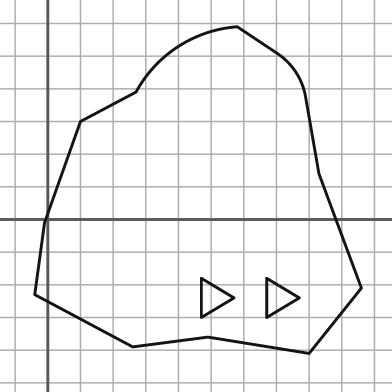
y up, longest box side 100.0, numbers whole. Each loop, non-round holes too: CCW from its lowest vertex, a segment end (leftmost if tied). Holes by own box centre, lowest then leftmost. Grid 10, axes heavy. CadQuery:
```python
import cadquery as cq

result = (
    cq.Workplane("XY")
    .moveTo(80.0, -41.0)
    .lineTo(96.0, -21.0)
    .lineTo(83.0, 14.0)
    .lineTo(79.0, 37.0)
    .threePointArc((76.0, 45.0), (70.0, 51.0))
    .lineTo(58.0, 59.0)
    .threePointArc((40.0, 53.0), (27.0, 39.0))
    .lineTo(10.0, 30.0)
    .lineTo(-1.0, -1.0)
    .lineTo(-4.0, -23.0)
    .lineTo(26.0, -39.0)
    .lineTo(49.0, -36.0)
    .close()
    .moveTo(47.0, -30.0)
    .lineTo(57.0, -24.0)
    .lineTo(47.0, -18.0)
    .close()
    .moveTo(67.0, -30.0)
    .lineTo(77.0, -24.0)
    .lineTo(67.0, -18.0)
    .close()
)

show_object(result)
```